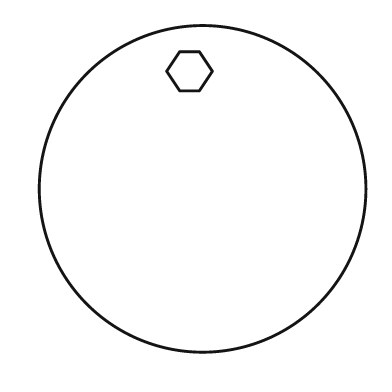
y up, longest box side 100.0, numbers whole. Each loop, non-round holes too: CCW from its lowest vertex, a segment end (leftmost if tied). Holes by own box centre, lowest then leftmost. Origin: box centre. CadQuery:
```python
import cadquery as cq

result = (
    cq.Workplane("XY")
    .moveTo(0.0, 0.0)
    .circle(50.0)
    .moveTo(-7.0, 30.0)
    .lineTo(-1.0, 30.0)
    .lineTo(3.0, 36.0)
    .lineTo(-1.0, 42.0)
    .lineTo(-7.0, 42.0)
    .lineTo(-11.0, 36.0)
    .close()
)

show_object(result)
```